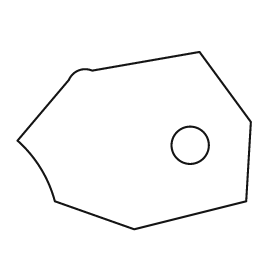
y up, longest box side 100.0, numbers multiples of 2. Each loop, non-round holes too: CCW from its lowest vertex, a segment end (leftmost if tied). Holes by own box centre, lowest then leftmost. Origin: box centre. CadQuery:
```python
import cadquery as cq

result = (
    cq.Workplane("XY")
    .moveTo(0.0, -38.0)
    .lineTo(48.0, -26.0)
    .lineTo(50.0, 8.0)
    .lineTo(28.0, 38.0)
    .lineTo(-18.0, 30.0)
    .threePointArc((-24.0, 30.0), (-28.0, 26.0))
    .lineTo(-50.0, 0.0)
    .threePointArc((-40.0, -12.0), (-34.0, -26.0))
    .close()
    .moveTo(24.0, -2.0)
    .circle(8.0)
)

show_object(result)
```